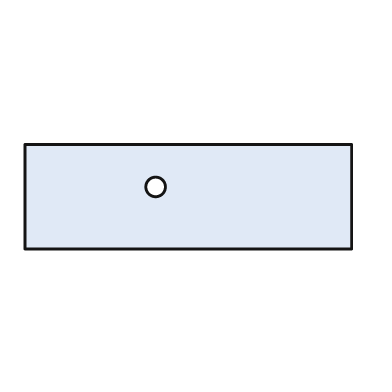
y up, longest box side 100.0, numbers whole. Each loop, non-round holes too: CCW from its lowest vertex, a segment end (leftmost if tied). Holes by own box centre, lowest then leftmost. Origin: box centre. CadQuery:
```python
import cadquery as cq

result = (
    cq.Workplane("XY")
    .moveTo(-50.0, -16.0)
    .lineTo(50.0, -16.0)
    .lineTo(50.0, 16.0)
    .lineTo(-50.0, 16.0)
    .close()
    .moveTo(-10.0, 3.0)
    .circle(3.0)
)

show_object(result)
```